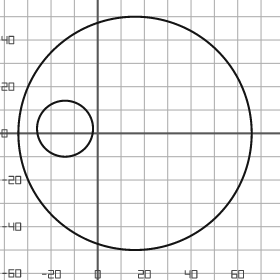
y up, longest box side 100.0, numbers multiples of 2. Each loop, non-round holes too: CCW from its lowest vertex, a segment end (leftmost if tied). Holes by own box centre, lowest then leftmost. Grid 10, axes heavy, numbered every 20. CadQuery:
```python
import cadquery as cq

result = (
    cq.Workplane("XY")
    .moveTo(16.0, 0.0)
    .circle(50.0)
    .moveTo(-14.0, 2.0)
    .circle(12.0)
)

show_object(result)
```